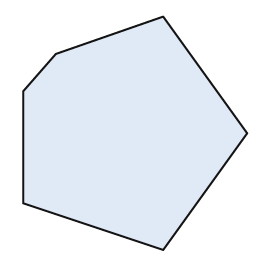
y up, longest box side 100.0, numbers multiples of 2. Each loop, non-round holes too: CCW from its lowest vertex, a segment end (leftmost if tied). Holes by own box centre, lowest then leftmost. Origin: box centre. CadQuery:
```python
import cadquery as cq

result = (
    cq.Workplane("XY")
    .moveTo(12.0, -50.0)
    .lineTo(48.0, 0.0)
    .lineTo(12.0, 50.0)
    .lineTo(-34.0, 34.0)
    .lineTo(-48.0, 18.0)
    .lineTo(-48.0, -30.0)
    .close()
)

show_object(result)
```